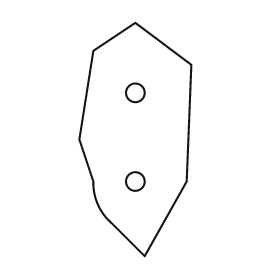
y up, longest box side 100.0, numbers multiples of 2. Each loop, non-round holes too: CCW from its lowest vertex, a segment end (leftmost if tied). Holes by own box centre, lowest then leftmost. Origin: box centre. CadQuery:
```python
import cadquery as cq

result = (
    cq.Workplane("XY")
    .moveTo(4.0, -50.0)
    .lineTo(22.0, -18.0)
    .lineTo(24.0, 32.0)
    .lineTo(0.0, 50.0)
    .lineTo(-18.0, 38.0)
    .lineTo(-24.0, 0.0)
    .lineTo(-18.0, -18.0)
    .threePointArc((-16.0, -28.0), (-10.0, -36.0))
    .close()
    .moveTo(0.0, -18.0)
    .circle(4.0)
    .moveTo(0.0, 20.0)
    .circle(4.0)
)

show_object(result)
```